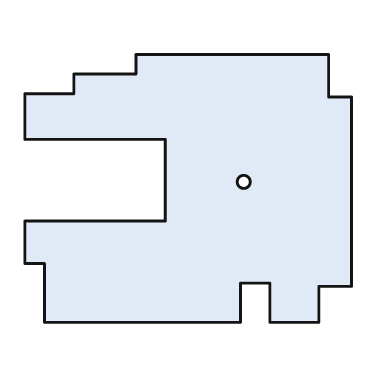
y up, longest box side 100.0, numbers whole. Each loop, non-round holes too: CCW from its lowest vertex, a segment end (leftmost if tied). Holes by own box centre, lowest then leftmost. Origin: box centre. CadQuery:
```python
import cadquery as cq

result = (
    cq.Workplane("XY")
    .moveTo(-44.0, -41.0)
    .lineTo(16.0, -41.0)
    .lineTo(16.0, -29.0)
    .lineTo(25.0, -29.0)
    .lineTo(25.0, -41.0)
    .lineTo(40.0, -41.0)
    .lineTo(40.0, -30.0)
    .lineTo(50.0, -30.0)
    .lineTo(50.0, 28.0)
    .lineTo(43.0, 28.0)
    .lineTo(43.0, 41.0)
    .lineTo(-16.0, 41.0)
    .lineTo(-16.0, 35.0)
    .lineTo(-35.0, 35.0)
    .lineTo(-35.0, 29.0)
    .lineTo(-50.0, 29.0)
    .lineTo(-50.0, 15.0)
    .lineTo(-7.0, 15.0)
    .lineTo(-7.0, -10.0)
    .lineTo(-50.0, -10.0)
    .lineTo(-50.0, -23.0)
    .lineTo(-44.0, -23.0)
    .close()
    .moveTo(17.0, 2.0)
    .circle(2.0)
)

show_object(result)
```